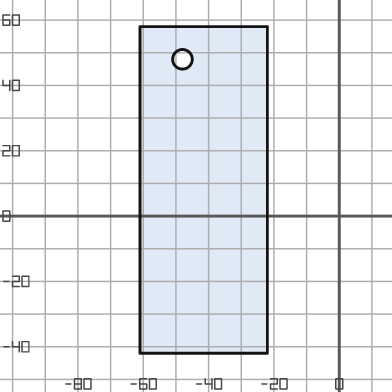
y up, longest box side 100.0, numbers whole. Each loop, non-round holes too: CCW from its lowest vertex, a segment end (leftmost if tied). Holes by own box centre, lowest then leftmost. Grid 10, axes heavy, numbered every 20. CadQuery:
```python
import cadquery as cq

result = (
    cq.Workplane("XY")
    .moveTo(-61.0, -42.0)
    .lineTo(-22.0, -42.0)
    .lineTo(-22.0, 58.0)
    .lineTo(-61.0, 58.0)
    .close()
    .moveTo(-48.0, 48.0)
    .circle(3.0)
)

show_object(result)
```